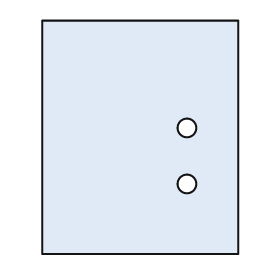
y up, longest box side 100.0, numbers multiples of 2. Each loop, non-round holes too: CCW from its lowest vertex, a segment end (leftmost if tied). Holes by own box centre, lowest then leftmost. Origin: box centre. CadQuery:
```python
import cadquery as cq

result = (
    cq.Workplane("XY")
    .moveTo(-42.0, -50.0)
    .lineTo(42.0, -50.0)
    .lineTo(42.0, 50.0)
    .lineTo(-42.0, 50.0)
    .close()
    .moveTo(20.0, -20.0)
    .circle(4.0)
    .moveTo(20.0, 4.0)
    .circle(4.0)
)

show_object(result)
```